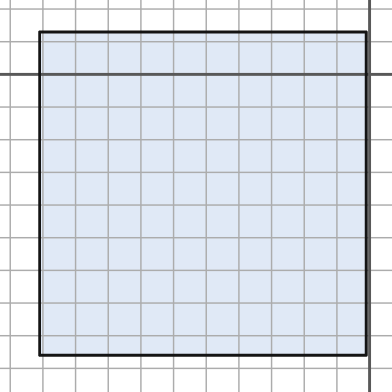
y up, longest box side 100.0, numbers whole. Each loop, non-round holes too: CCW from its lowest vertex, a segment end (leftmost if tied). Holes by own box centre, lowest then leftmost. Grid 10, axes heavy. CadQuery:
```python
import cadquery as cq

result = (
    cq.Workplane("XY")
    .moveTo(-101.0, -86.0)
    .lineTo(-1.0, -86.0)
    .lineTo(-1.0, 13.0)
    .lineTo(-101.0, 13.0)
    .close()
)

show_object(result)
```